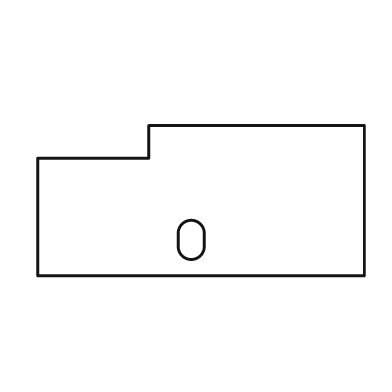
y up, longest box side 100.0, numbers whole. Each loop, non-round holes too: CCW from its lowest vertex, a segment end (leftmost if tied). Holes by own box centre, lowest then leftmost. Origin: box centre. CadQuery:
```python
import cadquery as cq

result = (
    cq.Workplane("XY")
    .moveTo(-50.0, -23.0)
    .lineTo(50.0, -23.0)
    .lineTo(50.0, 23.0)
    .lineTo(-16.0, 23.0)
    .lineTo(-16.0, 13.0)
    .lineTo(-50.0, 13.0)
    .close()
    .moveTo(-7.0, -14.0)
    .threePointArc((-3.0, -18.0), (1.0, -14.0))
    .lineTo(1.0, -10.0)
    .threePointArc((-3.0, -6.0), (-7.0, -10.0))
    .close()
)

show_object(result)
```